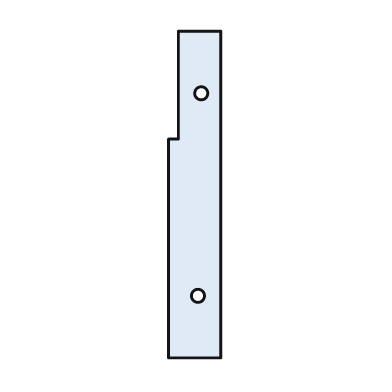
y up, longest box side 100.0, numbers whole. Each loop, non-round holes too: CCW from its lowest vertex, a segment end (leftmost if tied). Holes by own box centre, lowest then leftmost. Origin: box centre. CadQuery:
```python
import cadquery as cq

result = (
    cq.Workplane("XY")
    .moveTo(-8.0, -50.0)
    .lineTo(8.0, -50.0)
    .lineTo(8.0, 50.0)
    .lineTo(-5.0, 50.0)
    .lineTo(-5.0, 17.0)
    .lineTo(-8.0, 17.0)
    .close()
    .moveTo(1.0, -31.0)
    .circle(2.0)
    .moveTo(2.0, 31.0)
    .circle(2.0)
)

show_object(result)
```